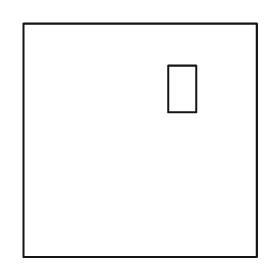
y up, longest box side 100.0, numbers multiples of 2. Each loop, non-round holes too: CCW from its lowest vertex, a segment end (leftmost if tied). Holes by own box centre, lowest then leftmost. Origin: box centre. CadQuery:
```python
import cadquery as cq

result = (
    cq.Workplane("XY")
    .moveTo(-50.0, -50.0)
    .lineTo(50.0, -50.0)
    .lineTo(50.0, 50.0)
    .lineTo(-50.0, 50.0)
    .close()
    .moveTo(12.0, 12.0)
    .lineTo(24.0, 12.0)
    .lineTo(24.0, 32.0)
    .lineTo(12.0, 32.0)
    .close()
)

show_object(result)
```